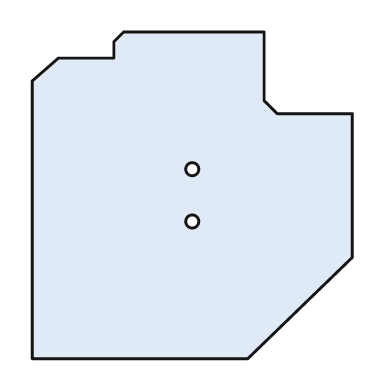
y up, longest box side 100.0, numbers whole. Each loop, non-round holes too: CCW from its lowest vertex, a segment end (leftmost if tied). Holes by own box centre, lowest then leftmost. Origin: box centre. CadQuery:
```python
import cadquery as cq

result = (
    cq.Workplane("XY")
    .moveTo(-49.0, -50.0)
    .lineTo(17.0, -50.0)
    .lineTo(49.0, -19.0)
    .lineTo(49.0, 25.0)
    .lineTo(26.0, 25.0)
    .lineTo(22.0, 29.0)
    .lineTo(22.0, 50.0)
    .lineTo(-21.0, 50.0)
    .lineTo(-24.0, 47.0)
    .lineTo(-24.0, 42.0)
    .lineTo(-41.0, 42.0)
    .lineTo(-49.0, 35.0)
    .close()
    .moveTo(0.0, -8.0)
    .circle(2.0)
    .moveTo(0.0, 8.0)
    .circle(2.0)
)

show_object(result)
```